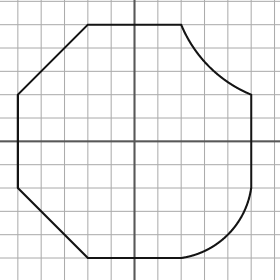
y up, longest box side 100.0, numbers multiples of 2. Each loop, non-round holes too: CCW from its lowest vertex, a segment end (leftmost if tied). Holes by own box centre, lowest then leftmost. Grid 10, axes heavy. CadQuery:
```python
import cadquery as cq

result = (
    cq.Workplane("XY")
    .moveTo(-20.0, -50.0)
    .lineTo(20.0, -50.0)
    .threePointArc((40.0, -40.0), (50.0, -20.0))
    .lineTo(50.0, 20.0)
    .threePointArc((32.0, 32.0), (20.0, 50.0))
    .lineTo(-20.0, 50.0)
    .lineTo(-50.0, 20.0)
    .lineTo(-50.0, -20.0)
    .close()
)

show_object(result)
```